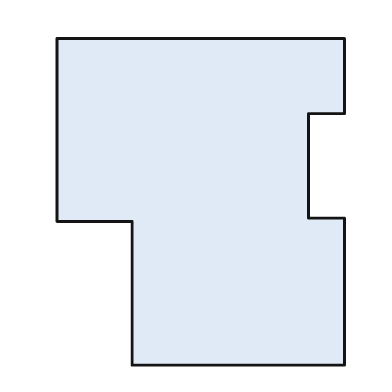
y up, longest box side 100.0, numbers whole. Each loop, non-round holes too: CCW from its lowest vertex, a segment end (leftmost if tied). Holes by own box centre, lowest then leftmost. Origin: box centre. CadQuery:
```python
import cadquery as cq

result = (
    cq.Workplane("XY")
    .moveTo(-21.0, -50.0)
    .lineTo(44.0, -50.0)
    .lineTo(44.0, -5.0)
    .lineTo(33.0, -5.0)
    .lineTo(33.0, 27.0)
    .lineTo(44.0, 27.0)
    .lineTo(44.0, 50.0)
    .lineTo(-44.0, 50.0)
    .lineTo(-44.0, -6.0)
    .lineTo(-21.0, -6.0)
    .close()
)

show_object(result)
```